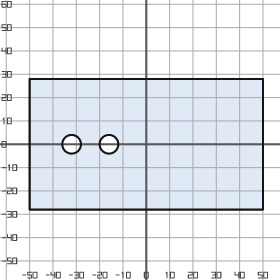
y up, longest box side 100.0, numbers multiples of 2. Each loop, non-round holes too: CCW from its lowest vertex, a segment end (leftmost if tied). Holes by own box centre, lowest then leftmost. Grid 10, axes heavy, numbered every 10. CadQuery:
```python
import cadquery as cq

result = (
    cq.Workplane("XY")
    .moveTo(-50.0, -28.0)
    .lineTo(50.0, -28.0)
    .lineTo(50.0, 28.0)
    .lineTo(-50.0, 28.0)
    .close()
    .moveTo(-32.0, 0.0)
    .circle(4.0)
    .moveTo(-16.0, 0.0)
    .circle(4.0)
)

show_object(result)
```